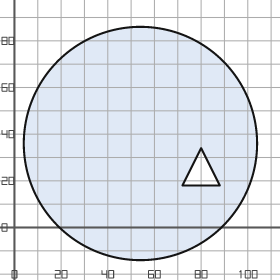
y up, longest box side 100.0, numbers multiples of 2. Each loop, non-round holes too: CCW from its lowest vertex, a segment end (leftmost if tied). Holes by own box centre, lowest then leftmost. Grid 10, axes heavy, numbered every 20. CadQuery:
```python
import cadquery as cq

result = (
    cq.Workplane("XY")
    .moveTo(54.0, 36.0)
    .circle(50.0)
    .moveTo(72.0, 18.0)
    .lineTo(88.0, 18.0)
    .lineTo(80.0, 34.0)
    .close()
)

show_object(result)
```